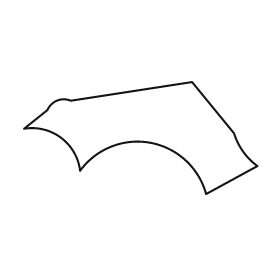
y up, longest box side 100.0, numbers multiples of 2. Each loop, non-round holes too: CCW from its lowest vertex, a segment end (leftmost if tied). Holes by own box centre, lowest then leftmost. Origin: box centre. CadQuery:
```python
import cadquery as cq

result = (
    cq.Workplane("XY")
    .moveTo(28.0, -24.0)
    .lineTo(50.0, -12.0)
    .threePointArc((44.0, -6.0), (40.0, 2.0))
    .lineTo(22.0, 24.0)
    .lineTo(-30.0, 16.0)
    .threePointArc((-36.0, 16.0), (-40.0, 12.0))
    .lineTo(-50.0, 4.0)
    .threePointArc((-34.0, 0.0), (-26.0, -14.0))
    .threePointArc((4.0, -2.0), (28.0, -24.0))
    .close()
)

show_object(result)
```